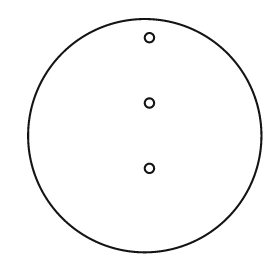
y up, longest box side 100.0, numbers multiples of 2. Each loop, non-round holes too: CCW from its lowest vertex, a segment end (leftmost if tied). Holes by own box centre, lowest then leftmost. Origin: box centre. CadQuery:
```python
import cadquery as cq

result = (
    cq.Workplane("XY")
    .moveTo(0.0, 0.0)
    .circle(50.0)
    .moveTo(2.0, -14.0)
    .circle(2.0)
    .moveTo(2.0, 14.0)
    .circle(2.0)
    .moveTo(2.0, 42.0)
    .circle(2.0)
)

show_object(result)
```